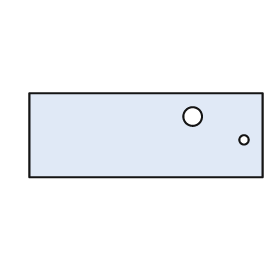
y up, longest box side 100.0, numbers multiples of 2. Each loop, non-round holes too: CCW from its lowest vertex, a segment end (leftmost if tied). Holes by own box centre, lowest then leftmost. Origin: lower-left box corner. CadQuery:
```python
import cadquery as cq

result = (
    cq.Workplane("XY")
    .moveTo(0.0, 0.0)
    .lineTo(100.0, 0.0)
    .lineTo(100.0, 36.0)
    .lineTo(0.0, 36.0)
    .close()
    .moveTo(92.0, 16.0)
    .circle(2.0)
    .moveTo(70.0, 26.0)
    .circle(4.0)
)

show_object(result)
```